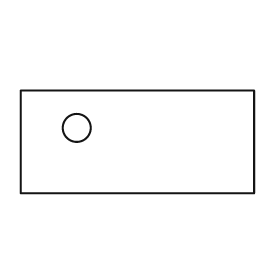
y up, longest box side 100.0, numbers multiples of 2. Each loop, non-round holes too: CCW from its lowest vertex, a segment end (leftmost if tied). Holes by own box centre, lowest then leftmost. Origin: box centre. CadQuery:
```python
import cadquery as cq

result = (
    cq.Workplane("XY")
    .moveTo(-50.0, -22.0)
    .lineTo(50.0, -22.0)
    .lineTo(50.0, 22.0)
    .lineTo(-50.0, 22.0)
    .close()
    .moveTo(-26.0, 6.0)
    .circle(6.0)
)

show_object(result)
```